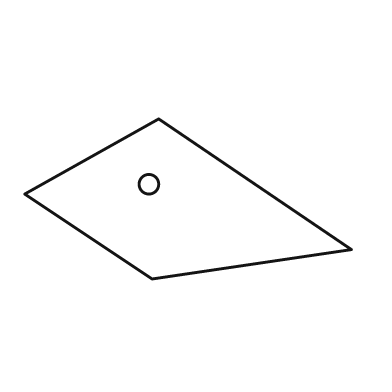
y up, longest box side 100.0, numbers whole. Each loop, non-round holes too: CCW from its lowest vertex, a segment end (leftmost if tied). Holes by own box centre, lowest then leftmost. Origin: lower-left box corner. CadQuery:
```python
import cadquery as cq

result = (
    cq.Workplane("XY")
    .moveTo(39.0, 0.0)
    .lineTo(100.0, 9.0)
    .lineTo(41.0, 49.0)
    .lineTo(0.0, 26.0)
    .close()
    .moveTo(38.0, 29.0)
    .circle(3.0)
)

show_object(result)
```